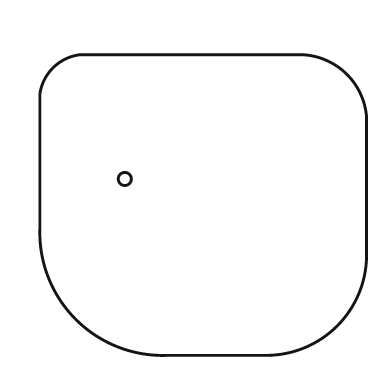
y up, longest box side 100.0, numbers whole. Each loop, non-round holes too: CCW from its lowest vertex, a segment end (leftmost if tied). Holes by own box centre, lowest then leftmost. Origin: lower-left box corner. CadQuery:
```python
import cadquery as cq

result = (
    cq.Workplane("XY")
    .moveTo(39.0, 0.0)
    .lineTo(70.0, 0.0)
    .threePointArc((91.0, 9.0), (100.0, 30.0))
    .lineTo(100.0, 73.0)
    .threePointArc((94.0, 86.0), (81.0, 92.0))
    .lineTo(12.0, 92.0)
    .threePointArc((4.0, 88.0), (0.0, 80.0))
    .lineTo(0.0, 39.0)
    .threePointArc((11.0, 11.0), (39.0, 0.0))
    .close()
    .moveTo(26.0, 54.0)
    .circle(2.0)
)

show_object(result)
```